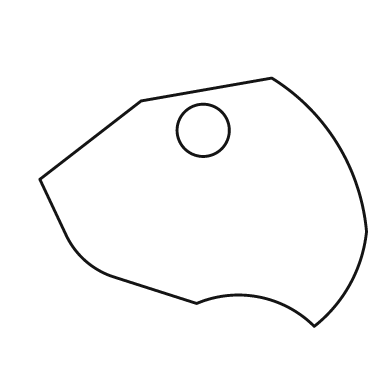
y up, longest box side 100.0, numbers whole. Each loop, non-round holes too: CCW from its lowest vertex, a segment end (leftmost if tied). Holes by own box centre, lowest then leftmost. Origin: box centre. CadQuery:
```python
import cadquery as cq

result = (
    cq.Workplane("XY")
    .moveTo(34.0, -38.0)
    .threePointArc((45.0, -25.0), (50.0, -9.0))
    .threePointArc((41.0, 18.0), (21.0, 38.0))
    .lineTo(-19.0, 31.0)
    .lineTo(-50.0, 7.0)
    .lineTo(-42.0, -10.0)
    .threePointArc((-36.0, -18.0), (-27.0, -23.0))
    .lineTo(-2.0, -31.0)
    .threePointArc((17.0, -29.0), (34.0, -38.0))
    .close()
    .moveTo(0.0, 22.0)
    .circle(8.0)
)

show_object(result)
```